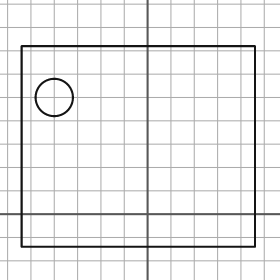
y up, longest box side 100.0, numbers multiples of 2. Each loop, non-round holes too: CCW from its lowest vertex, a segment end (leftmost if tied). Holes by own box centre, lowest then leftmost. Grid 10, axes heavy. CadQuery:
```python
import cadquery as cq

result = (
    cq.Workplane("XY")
    .moveTo(-54.0, -14.0)
    .lineTo(46.0, -14.0)
    .lineTo(46.0, 72.0)
    .lineTo(-54.0, 72.0)
    .close()
    .moveTo(-40.0, 50.0)
    .circle(8.0)
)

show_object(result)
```